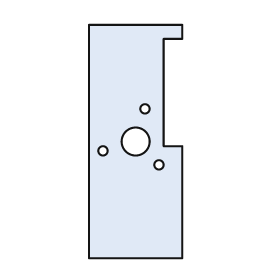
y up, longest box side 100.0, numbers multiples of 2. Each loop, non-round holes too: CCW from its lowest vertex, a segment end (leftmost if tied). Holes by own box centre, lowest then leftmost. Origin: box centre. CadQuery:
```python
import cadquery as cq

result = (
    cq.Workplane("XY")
    .moveTo(-20.0, -50.0)
    .lineTo(20.0, -50.0)
    .lineTo(20.0, -2.0)
    .lineTo(12.0, -2.0)
    .lineTo(12.0, 44.0)
    .lineTo(20.0, 44.0)
    .lineTo(20.0, 50.0)
    .lineTo(-20.0, 50.0)
    .close()
    .moveTo(10.0, -10.0)
    .circle(2.0)
    .moveTo(-14.0, -4.0)
    .circle(2.0)
    .moveTo(0.0, 0.0)
    .circle(6.0)
    .moveTo(4.0, 14.0)
    .circle(2.0)
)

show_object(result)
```